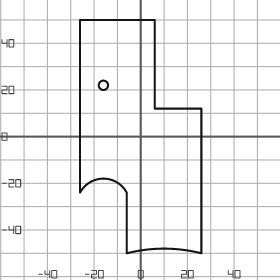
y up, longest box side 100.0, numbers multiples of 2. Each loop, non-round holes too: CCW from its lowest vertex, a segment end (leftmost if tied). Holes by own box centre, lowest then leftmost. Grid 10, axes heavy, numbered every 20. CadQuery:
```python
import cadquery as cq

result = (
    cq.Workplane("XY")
    .moveTo(-6.0, -50.0)
    .threePointArc((10.0, -48.0), (26.0, -50.0))
    .lineTo(26.0, 12.0)
    .lineTo(6.0, 12.0)
    .lineTo(6.0, 50.0)
    .lineTo(-26.0, 50.0)
    .lineTo(-26.0, -24.0)
    .threePointArc((-16.0, -18.0), (-6.0, -24.0))
    .close()
    .moveTo(-16.0, 22.0)
    .circle(2.0)
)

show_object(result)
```